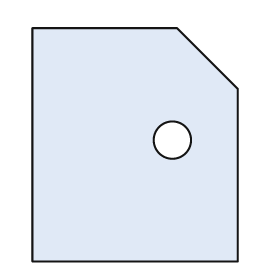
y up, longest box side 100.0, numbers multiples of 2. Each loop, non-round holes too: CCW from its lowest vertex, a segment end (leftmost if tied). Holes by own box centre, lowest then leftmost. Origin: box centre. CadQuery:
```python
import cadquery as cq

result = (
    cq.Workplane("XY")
    .moveTo(-44.0, -50.0)
    .lineTo(44.0, -50.0)
    .lineTo(44.0, 24.0)
    .lineTo(18.0, 50.0)
    .lineTo(-44.0, 50.0)
    .close()
    .moveTo(16.0, 2.0)
    .circle(8.0)
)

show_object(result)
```